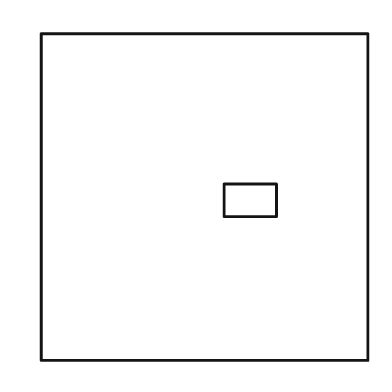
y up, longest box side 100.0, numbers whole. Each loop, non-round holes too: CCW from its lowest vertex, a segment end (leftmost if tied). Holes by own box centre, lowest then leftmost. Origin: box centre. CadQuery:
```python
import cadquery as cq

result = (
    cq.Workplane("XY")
    .moveTo(-50.0, -50.0)
    .lineTo(50.0, -50.0)
    .lineTo(50.0, 50.0)
    .lineTo(-50.0, 50.0)
    .close()
    .moveTo(6.0, -6.0)
    .lineTo(22.0, -6.0)
    .lineTo(22.0, 4.0)
    .lineTo(6.0, 4.0)
    .close()
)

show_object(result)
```